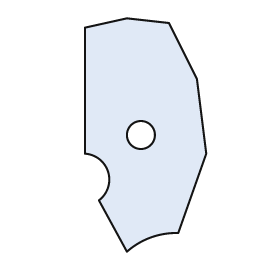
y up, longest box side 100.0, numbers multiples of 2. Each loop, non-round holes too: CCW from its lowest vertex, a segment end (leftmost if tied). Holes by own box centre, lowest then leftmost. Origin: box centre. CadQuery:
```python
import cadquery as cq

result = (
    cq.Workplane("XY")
    .moveTo(-8.0, -50.0)
    .threePointArc((2.0, -44.0), (14.0, -42.0))
    .lineTo(26.0, -8.0)
    .lineTo(22.0, 24.0)
    .lineTo(10.0, 48.0)
    .lineTo(-8.0, 50.0)
    .lineTo(-26.0, 46.0)
    .lineTo(-26.0, -8.0)
    .threePointArc((-16.0, -16.0), (-20.0, -28.0))
    .close()
    .moveTo(-2.0, 0.0)
    .circle(6.0)
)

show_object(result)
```